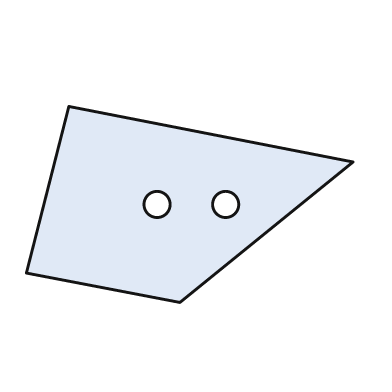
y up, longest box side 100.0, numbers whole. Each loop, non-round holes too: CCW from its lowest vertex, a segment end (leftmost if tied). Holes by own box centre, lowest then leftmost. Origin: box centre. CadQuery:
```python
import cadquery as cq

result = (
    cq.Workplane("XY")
    .moveTo(-3.0, -30.0)
    .lineTo(50.0, 13.0)
    .lineTo(-37.0, 30.0)
    .lineTo(-50.0, -21.0)
    .close()
    .moveTo(-10.0, 0.0)
    .circle(4.0)
    .moveTo(11.0, 0.0)
    .circle(4.0)
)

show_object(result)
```